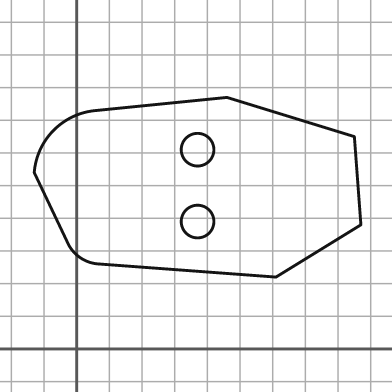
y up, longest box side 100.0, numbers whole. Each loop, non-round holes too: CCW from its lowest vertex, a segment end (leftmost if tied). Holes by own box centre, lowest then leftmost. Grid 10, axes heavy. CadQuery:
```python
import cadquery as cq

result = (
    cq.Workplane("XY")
    .moveTo(61.0, 22.0)
    .lineTo(87.0, 38.0)
    .lineTo(85.0, 65.0)
    .lineTo(46.0, 77.0)
    .lineTo(6.0, 73.0)
    .threePointArc((-7.0, 67.0), (-13.0, 54.0))
    .lineTo(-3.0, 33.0)
    .threePointArc((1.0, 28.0), (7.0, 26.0))
    .close()
    .moveTo(37.0, 39.0)
    .circle(5.0)
    .moveTo(37.0, 61.0)
    .circle(5.0)
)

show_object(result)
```